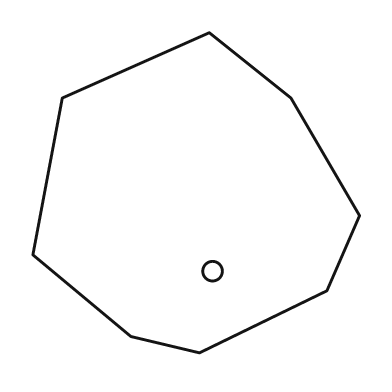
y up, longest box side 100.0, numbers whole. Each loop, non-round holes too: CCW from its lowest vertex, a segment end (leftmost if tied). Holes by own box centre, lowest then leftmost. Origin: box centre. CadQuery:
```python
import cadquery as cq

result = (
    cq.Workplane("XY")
    .moveTo(1.0, -49.0)
    .lineTo(40.0, -30.0)
    .lineTo(50.0, -7.0)
    .lineTo(29.0, 29.0)
    .lineTo(4.0, 49.0)
    .lineTo(-41.0, 29.0)
    .lineTo(-50.0, -19.0)
    .lineTo(-20.0, -44.0)
    .close()
    .moveTo(5.0, -24.0)
    .circle(3.0)
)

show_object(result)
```